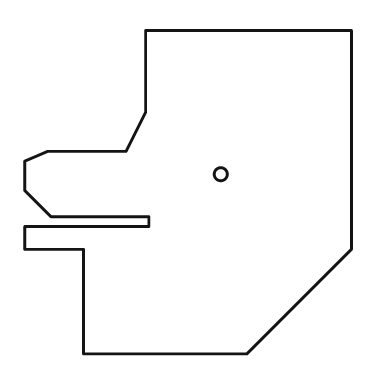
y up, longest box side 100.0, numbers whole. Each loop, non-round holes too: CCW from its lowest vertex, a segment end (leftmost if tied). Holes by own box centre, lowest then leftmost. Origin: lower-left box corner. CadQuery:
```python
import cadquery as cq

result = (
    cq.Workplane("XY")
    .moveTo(18.0, 0.0)
    .lineTo(68.0, 0.0)
    .lineTo(100.0, 32.0)
    .lineTo(100.0, 99.0)
    .lineTo(37.0, 99.0)
    .lineTo(37.0, 74.0)
    .lineTo(31.0, 62.0)
    .lineTo(7.0, 62.0)
    .lineTo(0.0, 59.0)
    .lineTo(0.0, 50.0)
    .lineTo(8.0, 42.0)
    .lineTo(38.0, 42.0)
    .lineTo(38.0, 39.0)
    .lineTo(0.0, 39.0)
    .lineTo(0.0, 32.0)
    .lineTo(18.0, 32.0)
    .close()
    .moveTo(60.0, 55.0)
    .circle(2.0)
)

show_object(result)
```